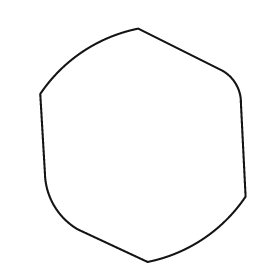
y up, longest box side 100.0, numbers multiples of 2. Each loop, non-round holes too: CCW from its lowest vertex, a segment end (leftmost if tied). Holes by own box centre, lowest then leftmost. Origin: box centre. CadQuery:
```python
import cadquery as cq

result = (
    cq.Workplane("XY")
    .moveTo(2.0, -50.0)
    .threePointArc((26.0, -40.0), (44.0, -22.0))
    .lineTo(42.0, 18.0)
    .threePointArc((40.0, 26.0), (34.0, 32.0))
    .lineTo(-2.0, 50.0)
    .threePointArc((-26.0, 40.0), (-44.0, 22.0))
    .lineTo(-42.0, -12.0)
    .threePointArc((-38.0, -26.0), (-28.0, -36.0))
    .close()
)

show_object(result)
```